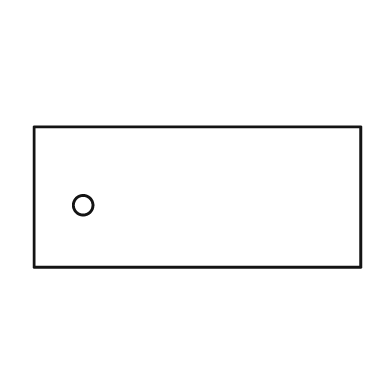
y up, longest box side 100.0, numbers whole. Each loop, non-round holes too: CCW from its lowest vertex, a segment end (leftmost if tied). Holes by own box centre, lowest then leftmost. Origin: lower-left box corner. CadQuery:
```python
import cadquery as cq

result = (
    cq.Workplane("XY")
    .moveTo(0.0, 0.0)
    .lineTo(100.0, 0.0)
    .lineTo(100.0, 43.0)
    .lineTo(0.0, 43.0)
    .close()
    .moveTo(15.0, 19.0)
    .circle(3.0)
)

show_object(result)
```